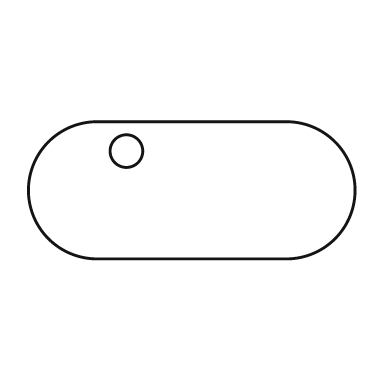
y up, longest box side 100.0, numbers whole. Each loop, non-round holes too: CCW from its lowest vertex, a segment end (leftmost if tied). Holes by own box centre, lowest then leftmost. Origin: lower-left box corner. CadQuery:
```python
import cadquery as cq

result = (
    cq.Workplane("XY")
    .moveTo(21.0, 0.0)
    .lineTo(79.0, 0.0)
    .threePointArc((100.0, 21.0), (79.0, 42.0))
    .lineTo(21.0, 42.0)
    .threePointArc((0.0, 21.0), (21.0, 0.0))
    .close()
    .moveTo(30.0, 33.0)
    .circle(5.0)
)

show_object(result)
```